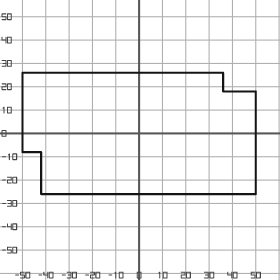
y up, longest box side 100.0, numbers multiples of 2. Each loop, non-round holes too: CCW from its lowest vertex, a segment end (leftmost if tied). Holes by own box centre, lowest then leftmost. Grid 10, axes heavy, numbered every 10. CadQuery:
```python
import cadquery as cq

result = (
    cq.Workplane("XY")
    .moveTo(-42.0, -26.0)
    .lineTo(50.0, -26.0)
    .lineTo(50.0, 18.0)
    .lineTo(36.0, 18.0)
    .lineTo(36.0, 26.0)
    .lineTo(-50.0, 26.0)
    .lineTo(-50.0, -8.0)
    .lineTo(-42.0, -8.0)
    .close()
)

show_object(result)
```